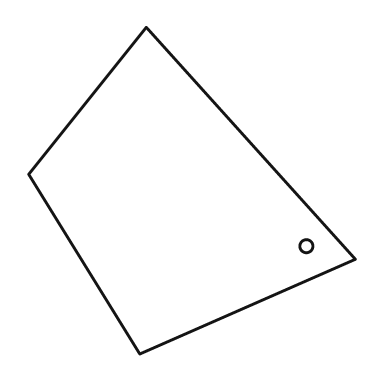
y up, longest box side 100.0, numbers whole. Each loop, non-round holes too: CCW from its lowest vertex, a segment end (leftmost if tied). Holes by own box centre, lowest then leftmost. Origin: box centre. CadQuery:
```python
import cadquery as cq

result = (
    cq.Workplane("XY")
    .moveTo(-16.0, -50.0)
    .lineTo(50.0, -21.0)
    .lineTo(-14.0, 50.0)
    .lineTo(-50.0, 5.0)
    .close()
    .moveTo(35.0, -17.0)
    .circle(2.0)
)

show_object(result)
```